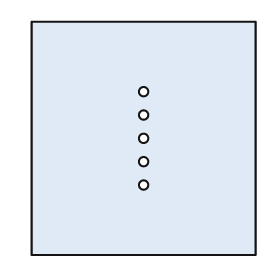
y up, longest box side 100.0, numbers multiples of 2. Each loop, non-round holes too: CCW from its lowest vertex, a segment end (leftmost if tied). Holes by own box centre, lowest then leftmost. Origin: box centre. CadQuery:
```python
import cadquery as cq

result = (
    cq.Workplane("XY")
    .moveTo(-48.0, -50.0)
    .lineTo(48.0, -50.0)
    .lineTo(48.0, 50.0)
    .lineTo(-48.0, 50.0)
    .close()
    .moveTo(0.0, -20.0)
    .circle(2.0)
    .moveTo(0.0, -10.0)
    .circle(2.0)
    .moveTo(0.0, 0.0)
    .circle(2.0)
    .moveTo(0.0, 10.0)
    .circle(2.0)
    .moveTo(0.0, 20.0)
    .circle(2.0)
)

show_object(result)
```